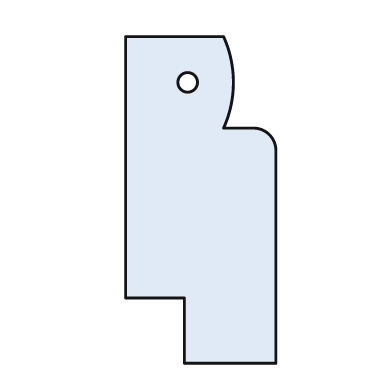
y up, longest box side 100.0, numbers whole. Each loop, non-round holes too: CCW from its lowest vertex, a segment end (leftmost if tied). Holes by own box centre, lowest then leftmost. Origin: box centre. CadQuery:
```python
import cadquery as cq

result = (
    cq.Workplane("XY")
    .moveTo(-5.0, -50.0)
    .lineTo(23.0, -50.0)
    .lineTo(23.0, 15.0)
    .threePointArc((21.0, 20.0), (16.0, 22.0))
    .lineTo(7.0, 22.0)
    .threePointArc((10.0, 36.0), (7.0, 50.0))
    .lineTo(-23.0, 50.0)
    .lineTo(-23.0, -30.0)
    .lineTo(-5.0, -30.0)
    .close()
    .moveTo(-4.0, 36.0)
    .circle(3.0)
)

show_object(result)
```